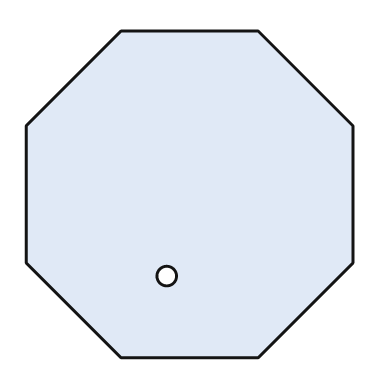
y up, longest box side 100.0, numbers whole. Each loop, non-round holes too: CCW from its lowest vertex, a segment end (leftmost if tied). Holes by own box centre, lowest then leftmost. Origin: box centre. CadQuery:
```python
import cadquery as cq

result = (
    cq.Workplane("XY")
    .moveTo(-21.0, -50.0)
    .lineTo(21.0, -50.0)
    .lineTo(50.0, -21.0)
    .lineTo(50.0, 21.0)
    .lineTo(21.0, 50.0)
    .lineTo(-21.0, 50.0)
    .lineTo(-50.0, 21.0)
    .lineTo(-50.0, -21.0)
    .close()
    .moveTo(-7.0, -25.0)
    .circle(3.0)
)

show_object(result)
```